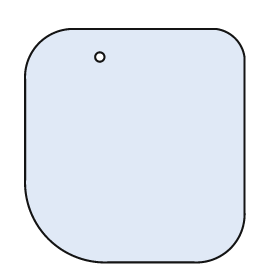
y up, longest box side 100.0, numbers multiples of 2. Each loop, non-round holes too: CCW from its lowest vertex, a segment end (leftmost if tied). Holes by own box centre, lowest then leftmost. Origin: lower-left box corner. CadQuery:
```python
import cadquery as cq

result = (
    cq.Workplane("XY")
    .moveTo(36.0, 0.0)
    .lineTo(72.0, 0.0)
    .threePointArc((88.0, 6.0), (94.0, 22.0))
    .lineTo(94.0, 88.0)
    .threePointArc((90.0, 96.0), (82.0, 100.0))
    .lineTo(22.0, 100.0)
    .threePointArc((6.0, 94.0), (0.0, 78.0))
    .lineTo(0.0, 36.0)
    .threePointArc((10.0, 10.0), (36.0, 0.0))
    .close()
    .moveTo(32.0, 88.0)
    .circle(2.0)
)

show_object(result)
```